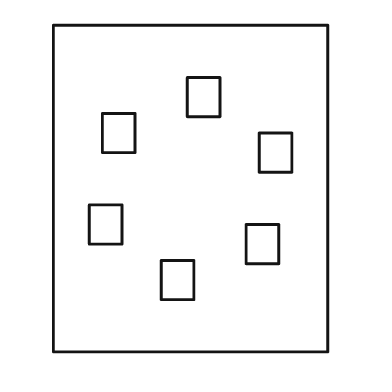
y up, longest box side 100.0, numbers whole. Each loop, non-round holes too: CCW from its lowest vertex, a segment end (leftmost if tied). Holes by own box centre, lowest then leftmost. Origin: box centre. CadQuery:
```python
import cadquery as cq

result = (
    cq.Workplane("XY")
    .moveTo(-42.0, -50.0)
    .lineTo(42.0, -50.0)
    .lineTo(42.0, 50.0)
    .lineTo(-42.0, 50.0)
    .close()
    .moveTo(-9.0, -34.0)
    .lineTo(1.0, -34.0)
    .lineTo(1.0, -22.0)
    .lineTo(-9.0, -22.0)
    .close()
    .moveTo(17.0, -23.0)
    .lineTo(27.0, -23.0)
    .lineTo(27.0, -11.0)
    .lineTo(17.0, -11.0)
    .close()
    .moveTo(-31.0, -17.0)
    .lineTo(-21.0, -17.0)
    .lineTo(-21.0, -5.0)
    .lineTo(-31.0, -5.0)
    .close()
    .moveTo(21.0, 5.0)
    .lineTo(31.0, 5.0)
    .lineTo(31.0, 17.0)
    .lineTo(21.0, 17.0)
    .close()
    .moveTo(-27.0, 11.0)
    .lineTo(-17.0, 11.0)
    .lineTo(-17.0, 23.0)
    .lineTo(-27.0, 23.0)
    .close()
    .moveTo(-1.0, 22.0)
    .lineTo(9.0, 22.0)
    .lineTo(9.0, 34.0)
    .lineTo(-1.0, 34.0)
    .close()
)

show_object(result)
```